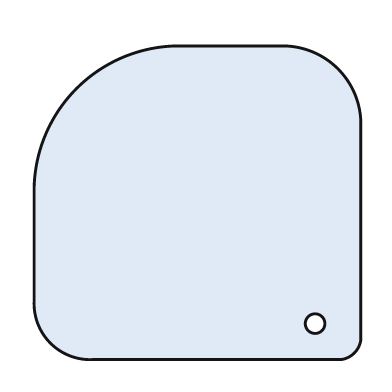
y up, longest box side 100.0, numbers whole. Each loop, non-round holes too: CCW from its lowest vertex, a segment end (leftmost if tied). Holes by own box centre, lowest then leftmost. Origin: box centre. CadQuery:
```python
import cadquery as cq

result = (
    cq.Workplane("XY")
    .moveTo(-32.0, -48.0)
    .lineTo(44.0, -48.0)
    .threePointArc((48.0, -46.0), (50.0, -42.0))
    .lineTo(50.0, 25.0)
    .threePointArc((43.0, 41.0), (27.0, 48.0))
    .lineTo(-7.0, 48.0)
    .threePointArc((-37.0, 35.0), (-50.0, 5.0))
    .lineTo(-50.0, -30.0)
    .threePointArc((-45.0, -43.0), (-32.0, -48.0))
    .close()
    .moveTo(36.0, -37.0)
    .circle(3.0)
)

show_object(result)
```